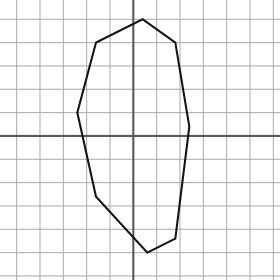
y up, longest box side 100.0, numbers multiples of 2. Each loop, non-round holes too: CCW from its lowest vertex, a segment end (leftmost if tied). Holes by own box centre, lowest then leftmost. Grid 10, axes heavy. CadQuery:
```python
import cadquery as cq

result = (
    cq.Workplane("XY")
    .moveTo(6.0, -50.0)
    .lineTo(18.0, -44.0)
    .lineTo(24.0, 4.0)
    .lineTo(18.0, 40.0)
    .lineTo(4.0, 50.0)
    .lineTo(-16.0, 40.0)
    .lineTo(-24.0, 10.0)
    .lineTo(-16.0, -26.0)
    .close()
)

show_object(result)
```